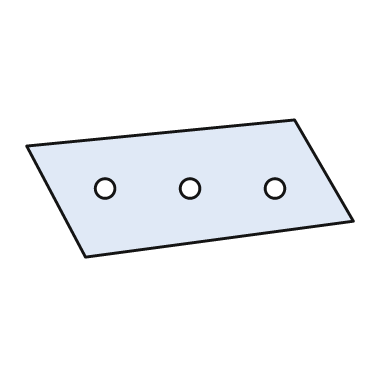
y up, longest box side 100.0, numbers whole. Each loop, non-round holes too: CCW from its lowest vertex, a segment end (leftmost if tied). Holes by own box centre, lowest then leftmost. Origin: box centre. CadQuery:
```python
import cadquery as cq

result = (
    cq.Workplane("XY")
    .moveTo(-32.0, -21.0)
    .lineTo(50.0, -10.0)
    .lineTo(32.0, 21.0)
    .lineTo(-50.0, 13.0)
    .close()
    .moveTo(-26.0, 0.0)
    .circle(3.0)
    .moveTo(0.0, 0.0)
    .circle(3.0)
    .moveTo(26.0, 0.0)
    .circle(3.0)
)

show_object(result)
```